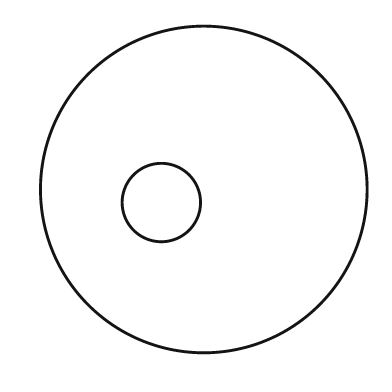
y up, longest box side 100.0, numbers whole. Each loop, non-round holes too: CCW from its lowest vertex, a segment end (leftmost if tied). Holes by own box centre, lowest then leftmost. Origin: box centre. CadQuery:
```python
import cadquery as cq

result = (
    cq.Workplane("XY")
    .moveTo(0.0, 0.0)
    .circle(50.0)
    .moveTo(-13.0, -4.0)
    .circle(12.0)
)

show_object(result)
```